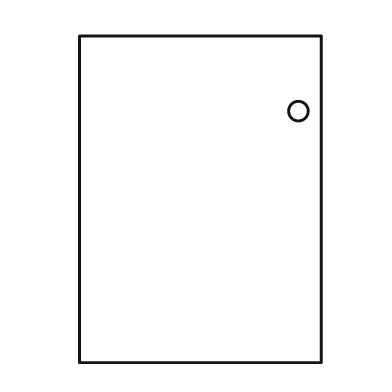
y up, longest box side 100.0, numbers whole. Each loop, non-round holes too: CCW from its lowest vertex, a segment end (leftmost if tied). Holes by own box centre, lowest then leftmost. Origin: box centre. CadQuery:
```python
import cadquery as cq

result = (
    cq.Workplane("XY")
    .moveTo(-37.0, -50.0)
    .lineTo(37.0, -50.0)
    .lineTo(37.0, 50.0)
    .lineTo(-37.0, 50.0)
    .close()
    .moveTo(30.0, 27.0)
    .circle(3.0)
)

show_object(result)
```